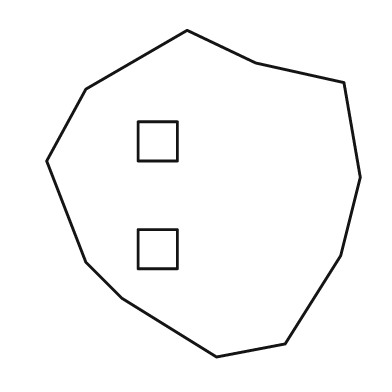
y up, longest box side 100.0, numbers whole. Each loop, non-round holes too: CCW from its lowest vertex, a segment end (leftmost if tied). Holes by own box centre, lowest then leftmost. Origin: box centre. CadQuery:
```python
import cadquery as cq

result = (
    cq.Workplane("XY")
    .moveTo(4.0, -50.0)
    .lineTo(25.0, -46.0)
    .lineTo(42.0, -19.0)
    .lineTo(48.0, 5.0)
    .lineTo(43.0, 34.0)
    .lineTo(16.0, 40.0)
    .lineTo(-5.0, 50.0)
    .lineTo(-36.0, 32.0)
    .lineTo(-48.0, 10.0)
    .lineTo(-36.0, -21.0)
    .lineTo(-25.0, -32.0)
    .close()
    .moveTo(-20.0, -23.0)
    .lineTo(-8.0, -23.0)
    .lineTo(-8.0, -11.0)
    .lineTo(-20.0, -11.0)
    .close()
    .moveTo(-20.0, 10.0)
    .lineTo(-8.0, 10.0)
    .lineTo(-8.0, 22.0)
    .lineTo(-20.0, 22.0)
    .close()
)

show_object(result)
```